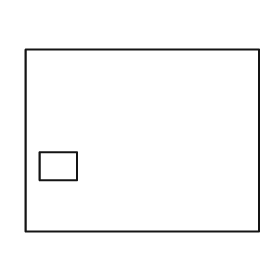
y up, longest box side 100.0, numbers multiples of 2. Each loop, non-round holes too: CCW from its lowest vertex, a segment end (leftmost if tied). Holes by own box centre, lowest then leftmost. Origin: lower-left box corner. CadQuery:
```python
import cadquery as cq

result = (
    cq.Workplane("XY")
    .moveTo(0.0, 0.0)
    .lineTo(100.0, 0.0)
    .lineTo(100.0, 78.0)
    .lineTo(0.0, 78.0)
    .close()
    .moveTo(6.0, 22.0)
    .lineTo(22.0, 22.0)
    .lineTo(22.0, 34.0)
    .lineTo(6.0, 34.0)
    .close()
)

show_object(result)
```